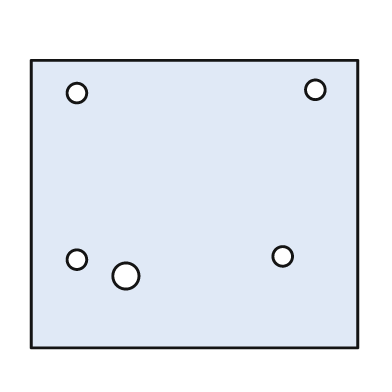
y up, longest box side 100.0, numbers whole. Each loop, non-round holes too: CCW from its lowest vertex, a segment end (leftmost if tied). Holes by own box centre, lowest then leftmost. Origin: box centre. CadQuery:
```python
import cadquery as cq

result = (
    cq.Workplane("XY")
    .moveTo(-50.0, -44.0)
    .lineTo(50.0, -44.0)
    .lineTo(50.0, 44.0)
    .lineTo(-50.0, 44.0)
    .close()
    .moveTo(-21.0, -22.0)
    .circle(4.0)
    .moveTo(-36.0, -17.0)
    .circle(3.0)
    .moveTo(27.0, -16.0)
    .circle(3.0)
    .moveTo(-36.0, 34.0)
    .circle(3.0)
    .moveTo(37.0, 35.0)
    .circle(3.0)
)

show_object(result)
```